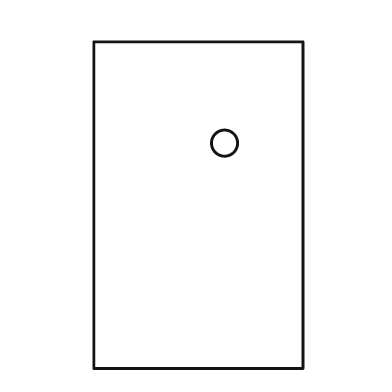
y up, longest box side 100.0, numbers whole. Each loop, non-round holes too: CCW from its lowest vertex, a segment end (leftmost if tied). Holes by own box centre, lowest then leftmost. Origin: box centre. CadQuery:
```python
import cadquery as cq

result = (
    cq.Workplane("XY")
    .moveTo(-32.0, -50.0)
    .lineTo(32.0, -50.0)
    .lineTo(32.0, 50.0)
    .lineTo(-32.0, 50.0)
    .close()
    .moveTo(8.0, 19.0)
    .circle(4.0)
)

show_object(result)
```